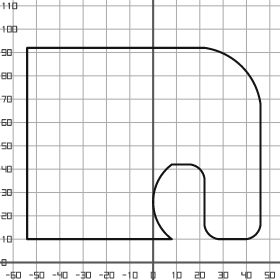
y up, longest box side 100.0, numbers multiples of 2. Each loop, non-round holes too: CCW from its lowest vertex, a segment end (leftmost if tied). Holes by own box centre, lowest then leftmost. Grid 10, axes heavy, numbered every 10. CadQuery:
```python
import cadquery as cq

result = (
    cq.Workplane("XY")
    .moveTo(-54.0, 10.0)
    .lineTo(8.0, 10.0)
    .threePointArc((0.0, 26.0), (8.0, 42.0))
    .lineTo(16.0, 42.0)
    .threePointArc((20.0, 40.0), (22.0, 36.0))
    .lineTo(22.0, 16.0)
    .threePointArc((24.0, 12.0), (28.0, 10.0))
    .lineTo(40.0, 10.0)
    .threePointArc((44.0, 12.0), (46.0, 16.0))
    .lineTo(46.0, 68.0)
    .threePointArc((38.0, 84.0), (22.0, 92.0))
    .lineTo(-54.0, 92.0)
    .close()
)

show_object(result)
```